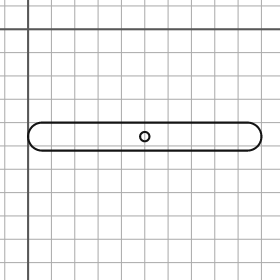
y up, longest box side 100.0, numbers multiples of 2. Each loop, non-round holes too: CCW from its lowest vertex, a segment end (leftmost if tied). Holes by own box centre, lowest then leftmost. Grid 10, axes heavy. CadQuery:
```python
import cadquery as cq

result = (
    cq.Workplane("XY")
    .moveTo(6.0, -52.0)
    .lineTo(94.0, -52.0)
    .threePointArc((100.0, -46.0), (94.0, -40.0))
    .lineTo(6.0, -40.0)
    .threePointArc((0.0, -46.0), (6.0, -52.0))
    .close()
    .moveTo(50.0, -46.0)
    .circle(2.0)
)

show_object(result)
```